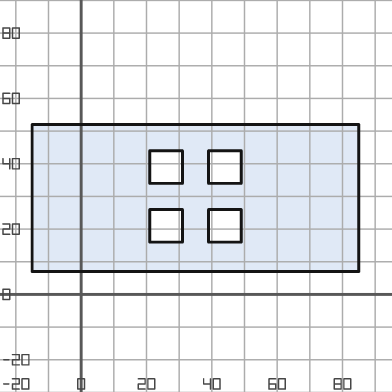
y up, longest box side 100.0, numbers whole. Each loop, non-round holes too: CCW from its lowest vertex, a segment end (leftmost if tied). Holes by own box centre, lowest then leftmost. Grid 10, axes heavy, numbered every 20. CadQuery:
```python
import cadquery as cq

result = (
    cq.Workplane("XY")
    .moveTo(-15.0, 7.0)
    .lineTo(85.0, 7.0)
    .lineTo(85.0, 52.0)
    .lineTo(-15.0, 52.0)
    .close()
    .moveTo(21.0, 16.0)
    .lineTo(31.0, 16.0)
    .lineTo(31.0, 26.0)
    .lineTo(21.0, 26.0)
    .close()
    .moveTo(39.0, 16.0)
    .lineTo(49.0, 16.0)
    .lineTo(49.0, 26.0)
    .lineTo(39.0, 26.0)
    .close()
    .moveTo(21.0, 34.0)
    .lineTo(31.0, 34.0)
    .lineTo(31.0, 44.0)
    .lineTo(21.0, 44.0)
    .close()
    .moveTo(39.0, 34.0)
    .lineTo(49.0, 34.0)
    .lineTo(49.0, 44.0)
    .lineTo(39.0, 44.0)
    .close()
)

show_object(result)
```